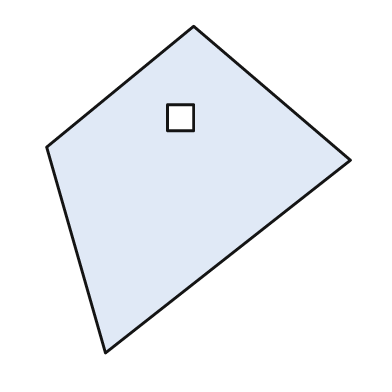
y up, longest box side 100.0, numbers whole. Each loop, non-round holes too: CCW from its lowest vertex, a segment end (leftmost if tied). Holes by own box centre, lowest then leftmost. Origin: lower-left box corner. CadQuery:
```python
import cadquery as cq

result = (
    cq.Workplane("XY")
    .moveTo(18.0, 0.0)
    .lineTo(93.0, 59.0)
    .lineTo(45.0, 100.0)
    .lineTo(0.0, 63.0)
    .close()
    .moveTo(37.0, 68.0)
    .lineTo(45.0, 68.0)
    .lineTo(45.0, 76.0)
    .lineTo(37.0, 76.0)
    .close()
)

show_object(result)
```